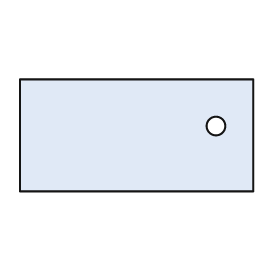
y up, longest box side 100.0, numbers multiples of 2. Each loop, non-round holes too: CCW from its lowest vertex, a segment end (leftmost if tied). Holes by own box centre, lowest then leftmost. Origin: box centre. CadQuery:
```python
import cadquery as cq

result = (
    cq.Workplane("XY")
    .moveTo(-50.0, -24.0)
    .lineTo(50.0, -24.0)
    .lineTo(50.0, 24.0)
    .lineTo(-50.0, 24.0)
    .close()
    .moveTo(34.0, 4.0)
    .circle(4.0)
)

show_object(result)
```